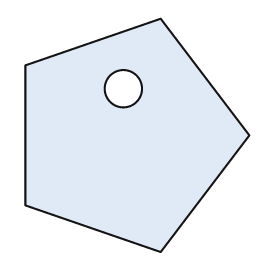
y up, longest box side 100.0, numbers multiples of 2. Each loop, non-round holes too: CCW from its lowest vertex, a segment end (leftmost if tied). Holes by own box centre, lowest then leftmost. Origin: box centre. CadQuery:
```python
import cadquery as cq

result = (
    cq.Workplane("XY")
    .moveTo(10.0, -50.0)
    .lineTo(48.0, 0.0)
    .lineTo(10.0, 50.0)
    .lineTo(-48.0, 30.0)
    .lineTo(-48.0, -30.0)
    .close()
    .moveTo(-6.0, 20.0)
    .circle(8.0)
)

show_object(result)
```